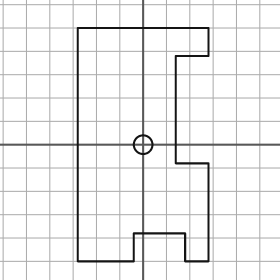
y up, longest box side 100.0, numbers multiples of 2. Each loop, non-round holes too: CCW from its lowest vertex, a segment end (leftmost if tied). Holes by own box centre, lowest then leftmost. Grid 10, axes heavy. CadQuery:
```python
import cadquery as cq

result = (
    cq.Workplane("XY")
    .moveTo(-28.0, -50.0)
    .lineTo(-4.0, -50.0)
    .lineTo(-4.0, -38.0)
    .lineTo(18.0, -38.0)
    .lineTo(18.0, -50.0)
    .lineTo(28.0, -50.0)
    .lineTo(28.0, -8.0)
    .lineTo(14.0, -8.0)
    .lineTo(14.0, 38.0)
    .lineTo(28.0, 38.0)
    .lineTo(28.0, 50.0)
    .lineTo(-28.0, 50.0)
    .close()
    .moveTo(0.0, 0.0)
    .circle(4.0)
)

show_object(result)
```